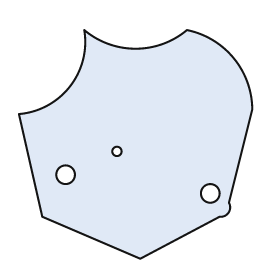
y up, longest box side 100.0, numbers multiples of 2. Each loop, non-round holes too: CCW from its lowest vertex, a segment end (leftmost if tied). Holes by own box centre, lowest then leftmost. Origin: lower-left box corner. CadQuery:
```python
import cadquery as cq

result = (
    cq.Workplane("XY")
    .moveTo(52.0, 0.0)
    .lineTo(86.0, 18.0)
    .threePointArc((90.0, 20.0), (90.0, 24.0))
    .lineTo(100.0, 64.0)
    .threePointArc((92.0, 86.0), (72.0, 98.0))
    .threePointArc((50.0, 90.0), (28.0, 98.0))
    .threePointArc((22.0, 74.0), (0.0, 62.0))
    .lineTo(10.0, 18.0)
    .close()
    .moveTo(82.0, 28.0)
    .circle(4.0)
    .moveTo(20.0, 36.0)
    .circle(4.0)
    .moveTo(42.0, 46.0)
    .circle(2.0)
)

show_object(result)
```